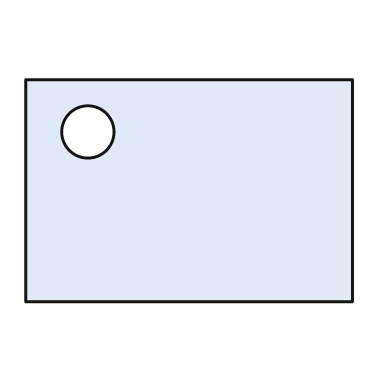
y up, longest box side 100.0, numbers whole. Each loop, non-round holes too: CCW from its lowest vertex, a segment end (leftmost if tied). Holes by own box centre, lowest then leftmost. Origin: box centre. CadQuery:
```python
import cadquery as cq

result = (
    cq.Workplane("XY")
    .moveTo(-50.0, -34.0)
    .lineTo(50.0, -34.0)
    .lineTo(50.0, 34.0)
    .lineTo(-50.0, 34.0)
    .close()
    .moveTo(-31.0, 18.0)
    .circle(8.0)
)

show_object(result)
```